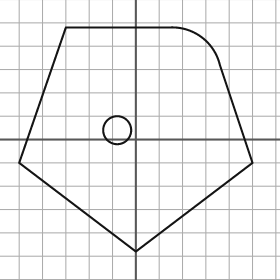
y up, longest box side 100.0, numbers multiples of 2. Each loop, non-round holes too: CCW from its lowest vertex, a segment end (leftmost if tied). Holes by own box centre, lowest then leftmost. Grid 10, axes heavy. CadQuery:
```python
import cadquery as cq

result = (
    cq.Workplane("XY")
    .moveTo(0.0, -48.0)
    .lineTo(50.0, -10.0)
    .lineTo(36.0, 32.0)
    .threePointArc((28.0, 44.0), (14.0, 48.0))
    .lineTo(-30.0, 48.0)
    .lineTo(-50.0, -10.0)
    .close()
    .moveTo(-8.0, 4.0)
    .circle(6.0)
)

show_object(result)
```